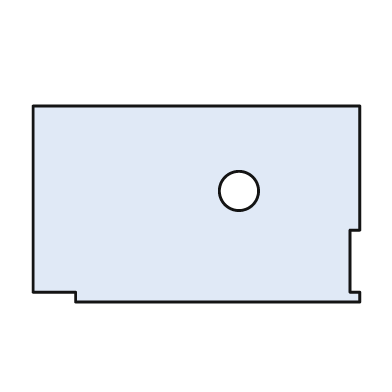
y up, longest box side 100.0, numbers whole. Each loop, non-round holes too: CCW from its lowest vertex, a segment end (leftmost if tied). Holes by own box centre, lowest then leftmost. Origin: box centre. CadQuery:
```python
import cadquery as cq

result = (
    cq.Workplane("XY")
    .moveTo(-37.0, -30.0)
    .lineTo(50.0, -30.0)
    .lineTo(50.0, -27.0)
    .lineTo(47.0, -27.0)
    .lineTo(47.0, -8.0)
    .lineTo(50.0, -8.0)
    .lineTo(50.0, 30.0)
    .lineTo(-50.0, 30.0)
    .lineTo(-50.0, -27.0)
    .lineTo(-37.0, -27.0)
    .close()
    .moveTo(13.0, 4.0)
    .circle(6.0)
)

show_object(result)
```